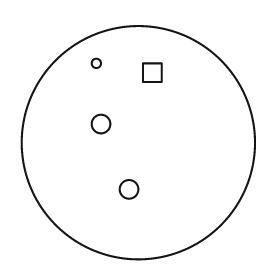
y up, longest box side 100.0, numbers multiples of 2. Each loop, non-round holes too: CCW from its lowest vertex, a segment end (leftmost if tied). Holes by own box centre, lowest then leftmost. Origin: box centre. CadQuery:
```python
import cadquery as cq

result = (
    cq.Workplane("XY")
    .moveTo(0.0, 0.0)
    .circle(50.0)
    .moveTo(-4.0, -20.0)
    .circle(4.0)
    .moveTo(-16.0, 8.0)
    .circle(4.0)
    .moveTo(2.0, 26.0)
    .lineTo(10.0, 26.0)
    .lineTo(10.0, 34.0)
    .lineTo(2.0, 34.0)
    .close()
    .moveTo(-18.0, 34.0)
    .circle(2.0)
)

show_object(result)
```